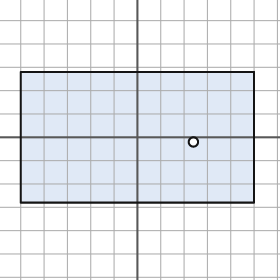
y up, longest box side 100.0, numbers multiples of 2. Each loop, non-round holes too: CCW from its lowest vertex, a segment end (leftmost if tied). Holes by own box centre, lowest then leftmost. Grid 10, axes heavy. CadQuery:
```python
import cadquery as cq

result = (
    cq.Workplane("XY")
    .moveTo(-50.0, -28.0)
    .lineTo(50.0, -28.0)
    .lineTo(50.0, 28.0)
    .lineTo(-50.0, 28.0)
    .close()
    .moveTo(24.0, -2.0)
    .circle(2.0)
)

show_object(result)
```